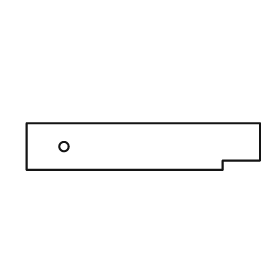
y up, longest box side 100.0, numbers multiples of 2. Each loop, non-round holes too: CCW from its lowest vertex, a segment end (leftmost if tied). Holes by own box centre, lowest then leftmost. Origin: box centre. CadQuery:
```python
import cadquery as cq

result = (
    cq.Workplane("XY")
    .moveTo(-50.0, -10.0)
    .lineTo(34.0, -10.0)
    .lineTo(34.0, -6.0)
    .lineTo(50.0, -6.0)
    .lineTo(50.0, 10.0)
    .lineTo(-50.0, 10.0)
    .close()
    .moveTo(-34.0, 0.0)
    .circle(2.0)
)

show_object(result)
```